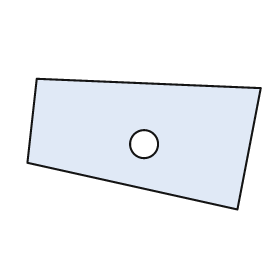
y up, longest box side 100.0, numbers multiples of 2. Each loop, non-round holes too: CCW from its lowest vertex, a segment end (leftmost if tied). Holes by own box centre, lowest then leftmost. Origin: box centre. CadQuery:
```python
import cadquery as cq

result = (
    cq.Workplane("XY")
    .moveTo(40.0, -28.0)
    .lineTo(50.0, 24.0)
    .lineTo(-46.0, 28.0)
    .lineTo(-50.0, -8.0)
    .close()
    .moveTo(0.0, 0.0)
    .circle(6.0)
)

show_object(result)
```